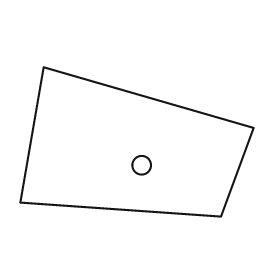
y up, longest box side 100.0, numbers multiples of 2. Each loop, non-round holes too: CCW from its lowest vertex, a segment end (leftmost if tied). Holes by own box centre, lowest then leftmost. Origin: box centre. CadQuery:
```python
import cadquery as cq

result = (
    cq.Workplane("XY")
    .moveTo(36.0, -32.0)
    .lineTo(50.0, 6.0)
    .lineTo(-40.0, 32.0)
    .lineTo(-50.0, -26.0)
    .close()
    .moveTo(2.0, -10.0)
    .circle(4.0)
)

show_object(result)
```